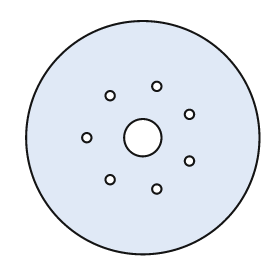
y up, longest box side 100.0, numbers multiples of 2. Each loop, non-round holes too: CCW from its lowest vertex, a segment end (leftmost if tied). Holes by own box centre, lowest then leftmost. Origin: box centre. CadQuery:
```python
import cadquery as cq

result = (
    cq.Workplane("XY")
    .moveTo(0.0, 0.0)
    .circle(50.0)
    .moveTo(6.0, -22.0)
    .circle(2.0)
    .moveTo(-14.0, -18.0)
    .circle(2.0)
    .moveTo(20.0, -10.0)
    .circle(2.0)
    .moveTo(-24.0, 0.0)
    .circle(2.0)
    .moveTo(0.0, 0.0)
    .circle(8.0)
    .moveTo(20.0, 10.0)
    .circle(2.0)
    .moveTo(-14.0, 18.0)
    .circle(2.0)
    .moveTo(6.0, 22.0)
    .circle(2.0)
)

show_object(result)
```